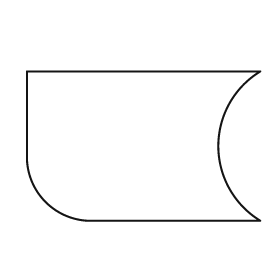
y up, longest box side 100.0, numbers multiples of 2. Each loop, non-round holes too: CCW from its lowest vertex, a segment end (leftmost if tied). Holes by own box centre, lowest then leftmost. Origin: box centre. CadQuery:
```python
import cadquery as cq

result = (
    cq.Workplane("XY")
    .moveTo(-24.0, -32.0)
    .lineTo(50.0, -32.0)
    .threePointArc((32.0, 0.0), (50.0, 32.0))
    .lineTo(-50.0, 32.0)
    .lineTo(-50.0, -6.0)
    .threePointArc((-42.0, -24.0), (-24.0, -32.0))
    .close()
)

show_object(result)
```